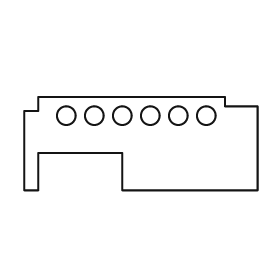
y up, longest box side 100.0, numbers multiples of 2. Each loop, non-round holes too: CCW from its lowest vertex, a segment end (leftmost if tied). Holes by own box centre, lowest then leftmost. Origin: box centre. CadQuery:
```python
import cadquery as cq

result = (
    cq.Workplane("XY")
    .moveTo(-50.0, -20.0)
    .lineTo(-44.0, -20.0)
    .lineTo(-44.0, -4.0)
    .lineTo(-8.0, -4.0)
    .lineTo(-8.0, -20.0)
    .lineTo(50.0, -20.0)
    .lineTo(50.0, 16.0)
    .lineTo(36.0, 16.0)
    .lineTo(36.0, 20.0)
    .lineTo(-44.0, 20.0)
    .lineTo(-44.0, 14.0)
    .lineTo(-50.0, 14.0)
    .close()
    .moveTo(-32.0, 12.0)
    .circle(4.0)
    .moveTo(-20.0, 12.0)
    .circle(4.0)
    .moveTo(-8.0, 12.0)
    .circle(4.0)
    .moveTo(4.0, 12.0)
    .circle(4.0)
    .moveTo(16.0, 12.0)
    .circle(4.0)
    .moveTo(28.0, 12.0)
    .circle(4.0)
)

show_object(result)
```